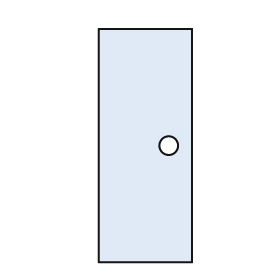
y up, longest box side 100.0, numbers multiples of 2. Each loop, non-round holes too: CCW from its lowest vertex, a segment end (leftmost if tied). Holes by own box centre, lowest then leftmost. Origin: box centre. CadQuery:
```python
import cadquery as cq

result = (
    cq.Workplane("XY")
    .moveTo(-20.0, -50.0)
    .lineTo(20.0, -50.0)
    .lineTo(20.0, 50.0)
    .lineTo(-20.0, 50.0)
    .close()
    .moveTo(10.0, 0.0)
    .circle(4.0)
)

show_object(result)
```